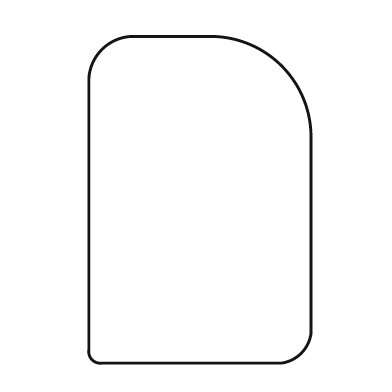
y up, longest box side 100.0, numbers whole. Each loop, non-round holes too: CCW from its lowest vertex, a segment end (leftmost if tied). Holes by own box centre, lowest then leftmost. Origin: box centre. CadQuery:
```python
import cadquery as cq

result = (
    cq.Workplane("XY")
    .moveTo(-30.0, -50.0)
    .lineTo(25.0, -50.0)
    .threePointArc((31.0, -47.0), (34.0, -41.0))
    .lineTo(34.0, 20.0)
    .threePointArc((25.0, 41.0), (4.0, 50.0))
    .lineTo(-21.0, 50.0)
    .threePointArc((-30.0, 46.0), (-34.0, 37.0))
    .lineTo(-34.0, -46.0)
    .threePointArc((-33.0, -49.0), (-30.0, -50.0))
    .close()
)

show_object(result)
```